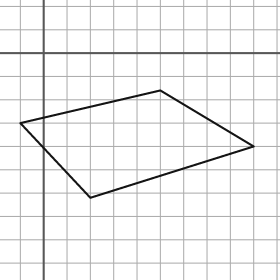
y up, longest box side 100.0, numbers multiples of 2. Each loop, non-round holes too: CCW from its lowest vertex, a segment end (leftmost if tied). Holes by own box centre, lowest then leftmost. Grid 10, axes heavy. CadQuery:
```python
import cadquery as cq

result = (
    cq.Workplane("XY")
    .moveTo(20.0, -62.0)
    .lineTo(90.0, -40.0)
    .lineTo(50.0, -16.0)
    .lineTo(-10.0, -30.0)
    .close()
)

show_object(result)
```